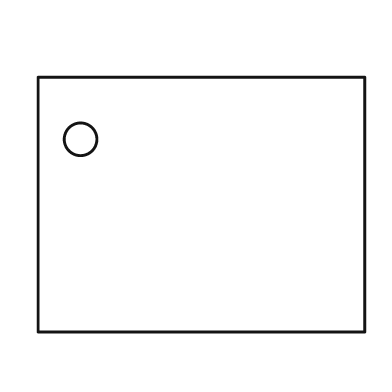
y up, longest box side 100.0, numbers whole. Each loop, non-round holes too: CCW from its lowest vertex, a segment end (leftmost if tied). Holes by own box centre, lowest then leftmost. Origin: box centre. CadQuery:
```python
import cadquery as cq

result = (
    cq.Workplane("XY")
    .moveTo(-50.0, -39.0)
    .lineTo(50.0, -39.0)
    .lineTo(50.0, 39.0)
    .lineTo(-50.0, 39.0)
    .close()
    .moveTo(-37.0, 20.0)
    .circle(5.0)
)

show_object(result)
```